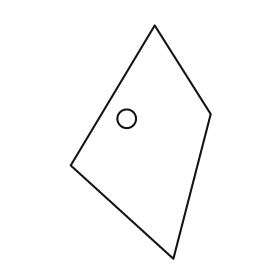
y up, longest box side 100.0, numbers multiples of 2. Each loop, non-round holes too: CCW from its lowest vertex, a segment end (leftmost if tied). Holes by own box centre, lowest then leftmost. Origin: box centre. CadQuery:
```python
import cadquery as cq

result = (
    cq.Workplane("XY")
    .moveTo(14.0, -50.0)
    .lineTo(30.0, 12.0)
    .lineTo(6.0, 50.0)
    .lineTo(-30.0, -10.0)
    .close()
    .moveTo(-6.0, 10.0)
    .circle(4.0)
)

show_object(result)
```